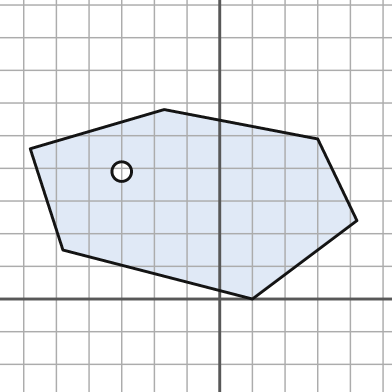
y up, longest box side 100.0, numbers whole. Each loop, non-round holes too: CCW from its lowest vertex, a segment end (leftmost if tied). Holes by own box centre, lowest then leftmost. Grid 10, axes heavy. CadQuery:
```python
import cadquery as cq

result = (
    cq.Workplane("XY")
    .moveTo(10.0, 0.0)
    .lineTo(42.0, 24.0)
    .lineTo(30.0, 49.0)
    .lineTo(-17.0, 58.0)
    .lineTo(-58.0, 46.0)
    .lineTo(-48.0, 15.0)
    .close()
    .moveTo(-30.0, 39.0)
    .circle(3.0)
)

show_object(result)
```